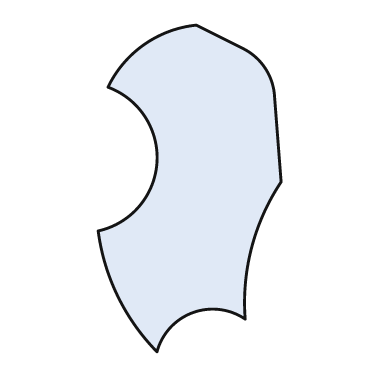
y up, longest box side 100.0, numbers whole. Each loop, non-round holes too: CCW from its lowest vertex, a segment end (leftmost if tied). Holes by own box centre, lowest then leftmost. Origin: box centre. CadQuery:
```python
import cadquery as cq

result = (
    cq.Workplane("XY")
    .moveTo(-10.0, -50.0)
    .threePointArc((1.0, -38.0), (17.0, -40.0))
    .threePointArc((19.0, -18.0), (28.0, 2.0))
    .lineTo(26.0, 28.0)
    .threePointArc((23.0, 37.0), (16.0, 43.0))
    .lineTo(2.0, 50.0)
    .threePointArc((-14.0, 44.0), (-25.0, 31.0))
    .threePointArc((-10.0, 8.0), (-28.0, -13.0))
    .threePointArc((-22.0, -33.0), (-10.0, -50.0))
    .close()
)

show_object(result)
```